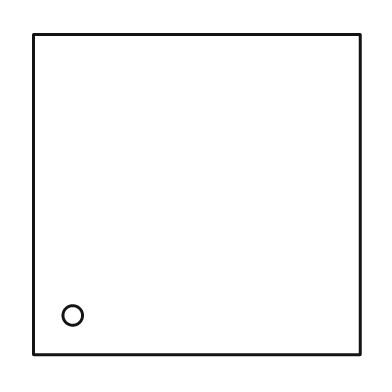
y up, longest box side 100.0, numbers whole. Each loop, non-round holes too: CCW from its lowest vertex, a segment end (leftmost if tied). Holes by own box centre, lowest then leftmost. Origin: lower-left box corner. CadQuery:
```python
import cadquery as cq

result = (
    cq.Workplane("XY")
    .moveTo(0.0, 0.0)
    .lineTo(100.0, 0.0)
    .lineTo(100.0, 98.0)
    .lineTo(0.0, 98.0)
    .close()
    .moveTo(12.0, 12.0)
    .circle(3.0)
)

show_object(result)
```